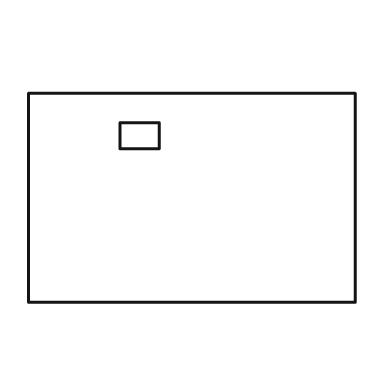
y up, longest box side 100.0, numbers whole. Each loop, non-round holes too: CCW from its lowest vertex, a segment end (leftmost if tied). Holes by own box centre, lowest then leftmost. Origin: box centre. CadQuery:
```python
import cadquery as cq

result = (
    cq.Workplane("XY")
    .moveTo(-50.0, -32.0)
    .lineTo(50.0, -32.0)
    .lineTo(50.0, 32.0)
    .lineTo(-50.0, 32.0)
    .close()
    .moveTo(-22.0, 15.0)
    .lineTo(-10.0, 15.0)
    .lineTo(-10.0, 23.0)
    .lineTo(-22.0, 23.0)
    .close()
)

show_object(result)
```